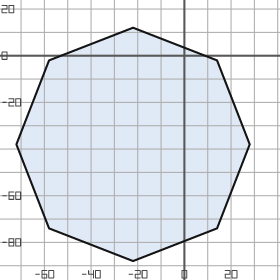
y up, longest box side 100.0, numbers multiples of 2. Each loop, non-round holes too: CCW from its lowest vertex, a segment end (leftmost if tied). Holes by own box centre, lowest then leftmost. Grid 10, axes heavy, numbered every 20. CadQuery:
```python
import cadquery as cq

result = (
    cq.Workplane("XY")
    .moveTo(-22.0, -88.0)
    .lineTo(14.0, -74.0)
    .lineTo(28.0, -38.0)
    .lineTo(14.0, -2.0)
    .lineTo(-22.0, 12.0)
    .lineTo(-58.0, -2.0)
    .lineTo(-72.0, -38.0)
    .lineTo(-58.0, -74.0)
    .close()
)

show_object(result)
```